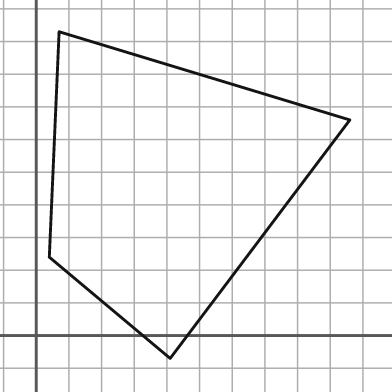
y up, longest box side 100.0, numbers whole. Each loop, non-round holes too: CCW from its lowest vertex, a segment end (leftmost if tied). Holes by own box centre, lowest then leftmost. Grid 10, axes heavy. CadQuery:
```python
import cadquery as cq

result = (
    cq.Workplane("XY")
    .moveTo(41.0, -7.0)
    .lineTo(96.0, 66.0)
    .lineTo(7.0, 93.0)
    .lineTo(4.0, 24.0)
    .close()
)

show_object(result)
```